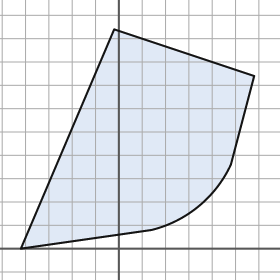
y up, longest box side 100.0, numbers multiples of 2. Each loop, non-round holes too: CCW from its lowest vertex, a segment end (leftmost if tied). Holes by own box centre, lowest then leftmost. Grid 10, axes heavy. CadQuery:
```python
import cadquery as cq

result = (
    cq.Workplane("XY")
    .moveTo(-42.0, 0.0)
    .lineTo(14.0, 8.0)
    .threePointArc((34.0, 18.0), (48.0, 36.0))
    .lineTo(58.0, 74.0)
    .lineTo(-2.0, 94.0)
    .close()
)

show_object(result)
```